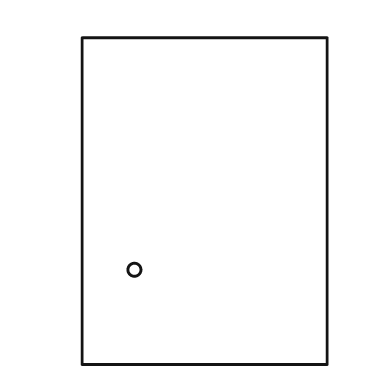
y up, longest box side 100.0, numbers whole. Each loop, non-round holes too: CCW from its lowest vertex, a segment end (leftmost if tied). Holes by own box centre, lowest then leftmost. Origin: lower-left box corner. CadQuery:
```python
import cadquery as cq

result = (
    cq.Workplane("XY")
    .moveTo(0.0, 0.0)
    .lineTo(75.0, 0.0)
    .lineTo(75.0, 100.0)
    .lineTo(0.0, 100.0)
    .close()
    .moveTo(16.0, 29.0)
    .circle(2.0)
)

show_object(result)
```